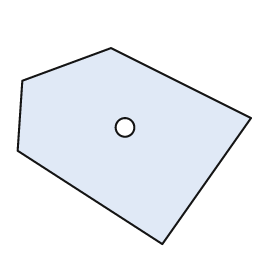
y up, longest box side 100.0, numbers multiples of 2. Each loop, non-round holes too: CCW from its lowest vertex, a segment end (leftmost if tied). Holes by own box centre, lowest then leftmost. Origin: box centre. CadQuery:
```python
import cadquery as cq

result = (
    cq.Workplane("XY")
    .moveTo(12.0, -42.0)
    .lineTo(50.0, 12.0)
    .lineTo(-10.0, 42.0)
    .lineTo(-48.0, 28.0)
    .lineTo(-50.0, -2.0)
    .close()
    .moveTo(-4.0, 8.0)
    .circle(4.0)
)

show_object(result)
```